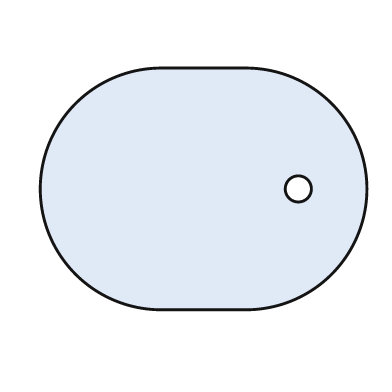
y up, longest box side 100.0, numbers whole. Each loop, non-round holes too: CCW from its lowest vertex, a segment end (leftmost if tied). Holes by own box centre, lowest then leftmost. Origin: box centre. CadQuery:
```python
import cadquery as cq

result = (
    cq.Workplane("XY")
    .moveTo(-13.0, -37.0)
    .lineTo(13.0, -37.0)
    .threePointArc((50.0, 0.0), (13.0, 37.0))
    .lineTo(-13.0, 37.0)
    .threePointArc((-50.0, 0.0), (-13.0, -37.0))
    .close()
    .moveTo(29.0, 0.0)
    .circle(4.0)
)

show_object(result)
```